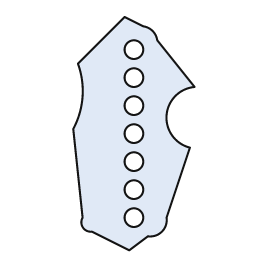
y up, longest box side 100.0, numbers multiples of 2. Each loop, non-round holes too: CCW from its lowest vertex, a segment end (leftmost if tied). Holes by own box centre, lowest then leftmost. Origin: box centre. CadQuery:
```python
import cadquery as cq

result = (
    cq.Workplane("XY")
    .moveTo(-2.0, -50.0)
    .lineTo(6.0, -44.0)
    .threePointArc((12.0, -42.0), (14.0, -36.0))
    .lineTo(24.0, -6.0)
    .threePointArc((14.0, 8.0), (26.0, 20.0))
    .lineTo(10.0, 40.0)
    .threePointArc((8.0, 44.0), (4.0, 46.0))
    .lineTo(-4.0, 50.0)
    .lineTo(-24.0, 30.0)
    .threePointArc((-22.0, 16.0), (-26.0, 2.0))
    .lineTo(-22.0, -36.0)
    .threePointArc((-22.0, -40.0), (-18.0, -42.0))
    .close()
    .moveTo(0.0, -36.0)
    .circle(4.0)
    .moveTo(0.0, -24.0)
    .circle(4.0)
    .moveTo(0.0, -12.0)
    .circle(4.0)
    .moveTo(0.0, 0.0)
    .circle(4.0)
    .moveTo(0.0, 12.0)
    .circle(4.0)
    .moveTo(0.0, 24.0)
    .circle(4.0)
    .moveTo(0.0, 36.0)
    .circle(4.0)
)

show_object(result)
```